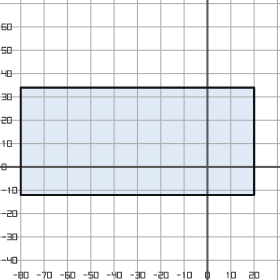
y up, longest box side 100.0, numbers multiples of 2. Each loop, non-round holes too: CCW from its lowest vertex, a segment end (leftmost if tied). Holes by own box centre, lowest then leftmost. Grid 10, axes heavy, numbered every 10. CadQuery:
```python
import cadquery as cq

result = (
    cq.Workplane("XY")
    .moveTo(-80.0, -12.0)
    .lineTo(20.0, -12.0)
    .lineTo(20.0, 34.0)
    .lineTo(-80.0, 34.0)
    .close()
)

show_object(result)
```